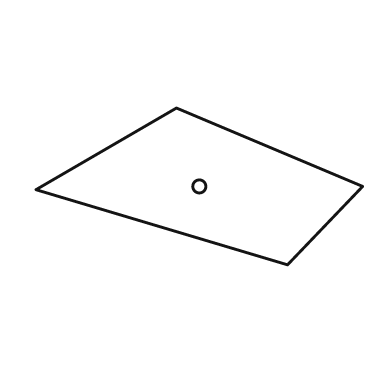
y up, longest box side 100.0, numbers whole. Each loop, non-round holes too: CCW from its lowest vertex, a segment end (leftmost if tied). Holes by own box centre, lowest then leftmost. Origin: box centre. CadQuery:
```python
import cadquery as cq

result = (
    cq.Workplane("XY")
    .moveTo(27.0, -24.0)
    .lineTo(50.0, 0.0)
    .lineTo(-7.0, 24.0)
    .lineTo(-50.0, -1.0)
    .close()
    .moveTo(0.0, 0.0)
    .circle(2.0)
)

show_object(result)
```